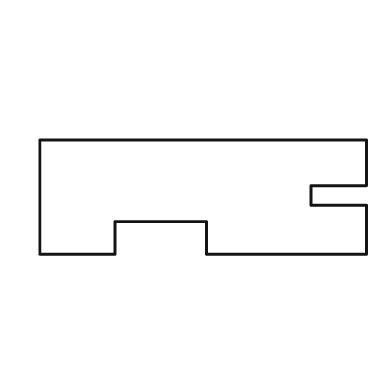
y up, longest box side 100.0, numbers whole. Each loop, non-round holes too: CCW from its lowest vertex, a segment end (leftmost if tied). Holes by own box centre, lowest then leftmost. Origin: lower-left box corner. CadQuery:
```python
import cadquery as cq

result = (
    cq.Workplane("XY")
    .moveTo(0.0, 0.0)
    .lineTo(23.0, 0.0)
    .lineTo(23.0, 10.0)
    .lineTo(51.0, 10.0)
    .lineTo(51.0, 0.0)
    .lineTo(100.0, 0.0)
    .lineTo(100.0, 15.0)
    .lineTo(83.0, 15.0)
    .lineTo(83.0, 21.0)
    .lineTo(100.0, 21.0)
    .lineTo(100.0, 35.0)
    .lineTo(0.0, 35.0)
    .close()
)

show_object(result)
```